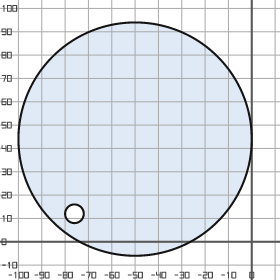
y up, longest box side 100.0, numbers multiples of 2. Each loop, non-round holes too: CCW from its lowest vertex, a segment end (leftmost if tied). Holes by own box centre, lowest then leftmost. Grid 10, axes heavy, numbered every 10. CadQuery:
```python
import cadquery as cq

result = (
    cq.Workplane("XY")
    .moveTo(-50.0, 44.0)
    .circle(50.0)
    .moveTo(-76.0, 12.0)
    .circle(4.0)
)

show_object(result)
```